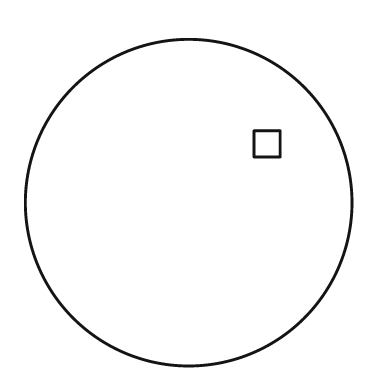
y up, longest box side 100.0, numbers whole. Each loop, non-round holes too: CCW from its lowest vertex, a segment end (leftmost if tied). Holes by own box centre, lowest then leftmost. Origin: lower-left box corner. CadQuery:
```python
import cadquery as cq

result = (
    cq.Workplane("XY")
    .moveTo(50.0, 50.0)
    .circle(50.0)
    .moveTo(70.0, 64.0)
    .lineTo(78.0, 64.0)
    .lineTo(78.0, 72.0)
    .lineTo(70.0, 72.0)
    .close()
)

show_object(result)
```